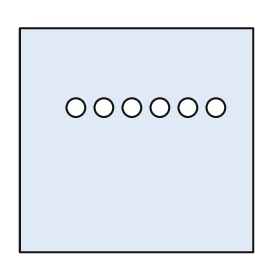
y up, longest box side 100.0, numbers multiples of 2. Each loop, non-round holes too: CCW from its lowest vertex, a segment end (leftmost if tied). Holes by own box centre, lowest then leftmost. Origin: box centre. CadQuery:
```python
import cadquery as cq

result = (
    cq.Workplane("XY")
    .moveTo(-50.0, -48.0)
    .lineTo(50.0, -48.0)
    .lineTo(50.0, 48.0)
    .lineTo(-50.0, 48.0)
    .close()
    .moveTo(-26.0, 14.0)
    .circle(4.0)
    .moveTo(-14.0, 14.0)
    .circle(4.0)
    .moveTo(-2.0, 14.0)
    .circle(4.0)
    .moveTo(10.0, 14.0)
    .circle(4.0)
    .moveTo(22.0, 14.0)
    .circle(4.0)
    .moveTo(34.0, 14.0)
    .circle(4.0)
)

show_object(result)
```